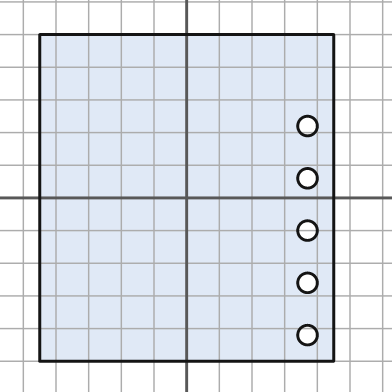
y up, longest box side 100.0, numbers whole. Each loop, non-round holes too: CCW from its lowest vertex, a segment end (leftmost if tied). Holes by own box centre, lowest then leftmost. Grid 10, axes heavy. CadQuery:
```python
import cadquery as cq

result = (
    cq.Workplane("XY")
    .moveTo(-45.0, -50.0)
    .lineTo(45.0, -50.0)
    .lineTo(45.0, 50.0)
    .lineTo(-45.0, 50.0)
    .close()
    .moveTo(37.0, -42.0)
    .circle(3.0)
    .moveTo(37.0, -26.0)
    .circle(3.0)
    .moveTo(37.0, -10.0)
    .circle(3.0)
    .moveTo(37.0, 6.0)
    .circle(3.0)
    .moveTo(37.0, 22.0)
    .circle(3.0)
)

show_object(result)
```